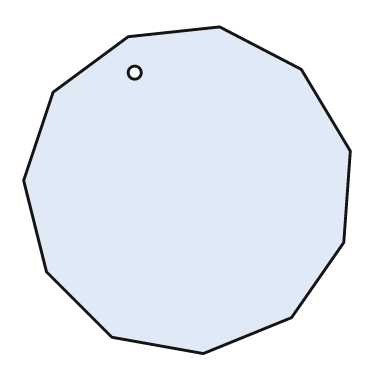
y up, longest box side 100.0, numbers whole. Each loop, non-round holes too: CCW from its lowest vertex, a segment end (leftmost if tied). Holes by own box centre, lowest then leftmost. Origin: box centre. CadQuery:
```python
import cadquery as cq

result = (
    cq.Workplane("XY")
    .moveTo(5.0, -50.0)
    .lineTo(32.0, -39.0)
    .lineTo(48.0, -16.0)
    .lineTo(50.0, 12.0)
    .lineTo(35.0, 37.0)
    .lineTo(10.0, 50.0)
    .lineTo(-18.0, 47.0)
    .lineTo(-41.0, 30.0)
    .lineTo(-50.0, 3.0)
    .lineTo(-43.0, -25.0)
    .lineTo(-23.0, -45.0)
    .close()
    .moveTo(-16.0, 36.0)
    .circle(2.0)
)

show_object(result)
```